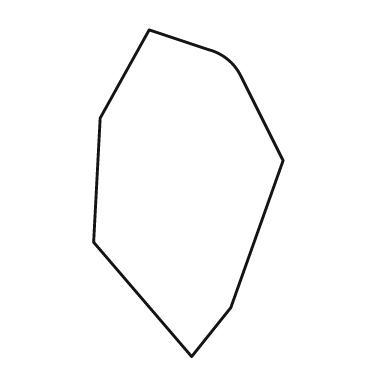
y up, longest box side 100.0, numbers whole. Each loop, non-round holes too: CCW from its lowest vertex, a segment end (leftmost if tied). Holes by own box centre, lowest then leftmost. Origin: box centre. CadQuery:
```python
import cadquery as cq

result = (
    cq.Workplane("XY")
    .moveTo(1.0, -50.0)
    .lineTo(13.0, -35.0)
    .lineTo(29.0, 10.0)
    .lineTo(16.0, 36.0)
    .threePointArc((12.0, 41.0), (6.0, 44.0))
    .lineTo(-12.0, 50.0)
    .lineTo(-27.0, 23.0)
    .lineTo(-29.0, -15.0)
    .close()
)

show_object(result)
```